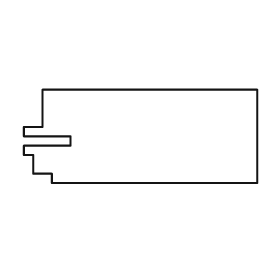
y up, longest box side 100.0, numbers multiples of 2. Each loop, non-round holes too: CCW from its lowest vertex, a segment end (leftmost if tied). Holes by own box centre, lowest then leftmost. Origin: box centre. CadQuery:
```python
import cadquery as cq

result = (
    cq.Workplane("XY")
    .moveTo(-38.0, -20.0)
    .lineTo(50.0, -20.0)
    .lineTo(50.0, 20.0)
    .lineTo(-42.0, 20.0)
    .lineTo(-42.0, 4.0)
    .lineTo(-50.0, 4.0)
    .lineTo(-50.0, 0.0)
    .lineTo(-30.0, 0.0)
    .lineTo(-30.0, -4.0)
    .lineTo(-50.0, -4.0)
    .lineTo(-50.0, -8.0)
    .lineTo(-46.0, -8.0)
    .lineTo(-46.0, -16.0)
    .lineTo(-38.0, -16.0)
    .close()
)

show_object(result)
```